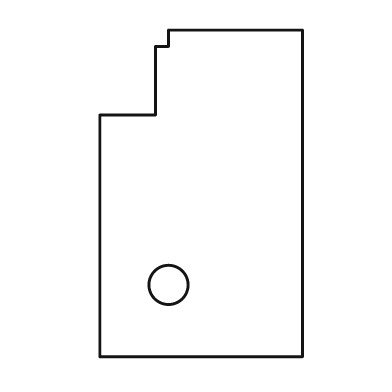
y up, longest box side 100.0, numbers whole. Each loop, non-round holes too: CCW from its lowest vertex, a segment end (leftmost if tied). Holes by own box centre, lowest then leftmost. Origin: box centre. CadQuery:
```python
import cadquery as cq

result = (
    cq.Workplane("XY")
    .moveTo(-31.0, -50.0)
    .lineTo(31.0, -50.0)
    .lineTo(31.0, 50.0)
    .lineTo(-10.0, 50.0)
    .lineTo(-10.0, 45.0)
    .lineTo(-14.0, 45.0)
    .lineTo(-14.0, 24.0)
    .lineTo(-31.0, 24.0)
    .close()
    .moveTo(-10.0, -28.0)
    .circle(6.0)
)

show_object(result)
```